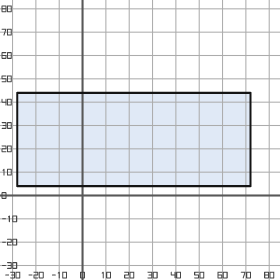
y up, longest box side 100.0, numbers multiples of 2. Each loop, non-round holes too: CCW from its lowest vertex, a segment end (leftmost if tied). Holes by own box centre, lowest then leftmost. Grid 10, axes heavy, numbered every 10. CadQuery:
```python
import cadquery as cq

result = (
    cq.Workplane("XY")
    .moveTo(-28.0, 4.0)
    .lineTo(72.0, 4.0)
    .lineTo(72.0, 44.0)
    .lineTo(-28.0, 44.0)
    .close()
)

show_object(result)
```